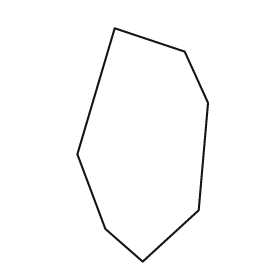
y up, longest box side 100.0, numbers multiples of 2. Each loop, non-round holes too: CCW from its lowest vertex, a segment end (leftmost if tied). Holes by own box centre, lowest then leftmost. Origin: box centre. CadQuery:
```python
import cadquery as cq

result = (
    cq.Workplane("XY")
    .moveTo(0.0, -50.0)
    .lineTo(24.0, -28.0)
    .lineTo(28.0, 18.0)
    .lineTo(18.0, 40.0)
    .lineTo(-12.0, 50.0)
    .lineTo(-28.0, -4.0)
    .lineTo(-16.0, -36.0)
    .close()
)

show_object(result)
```